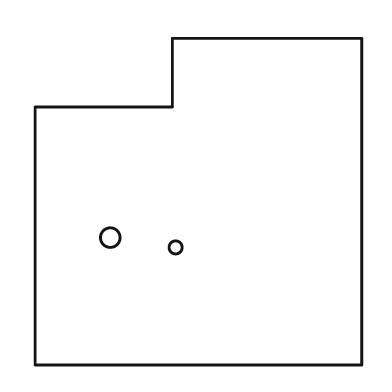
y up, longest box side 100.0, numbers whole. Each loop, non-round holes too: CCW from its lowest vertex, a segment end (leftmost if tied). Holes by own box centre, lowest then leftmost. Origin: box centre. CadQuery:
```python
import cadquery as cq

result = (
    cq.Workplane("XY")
    .moveTo(-50.0, -50.0)
    .lineTo(50.0, -50.0)
    .lineTo(50.0, 50.0)
    .lineTo(-8.0, 50.0)
    .lineTo(-8.0, 29.0)
    .lineTo(-50.0, 29.0)
    .close()
    .moveTo(-7.0, -14.0)
    .circle(2.0)
    .moveTo(-27.0, -11.0)
    .circle(3.0)
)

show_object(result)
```